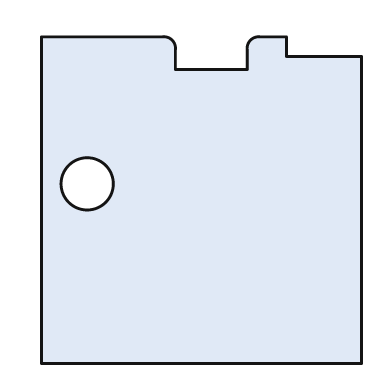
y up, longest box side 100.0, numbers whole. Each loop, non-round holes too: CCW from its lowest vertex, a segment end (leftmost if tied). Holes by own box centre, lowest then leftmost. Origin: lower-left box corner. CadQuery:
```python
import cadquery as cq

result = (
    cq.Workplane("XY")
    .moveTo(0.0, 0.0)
    .lineTo(98.0, 0.0)
    .lineTo(98.0, 94.0)
    .lineTo(75.0, 94.0)
    .lineTo(75.0, 100.0)
    .lineTo(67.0, 100.0)
    .threePointArc((64.0, 99.0), (63.0, 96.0))
    .lineTo(63.0, 90.0)
    .lineTo(41.0, 90.0)
    .lineTo(41.0, 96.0)
    .threePointArc((40.0, 99.0), (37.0, 100.0))
    .lineTo(0.0, 100.0)
    .close()
    .moveTo(14.0, 55.0)
    .circle(8.0)
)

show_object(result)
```